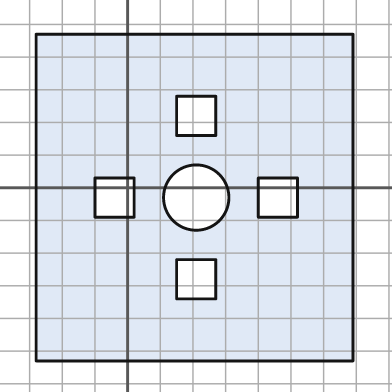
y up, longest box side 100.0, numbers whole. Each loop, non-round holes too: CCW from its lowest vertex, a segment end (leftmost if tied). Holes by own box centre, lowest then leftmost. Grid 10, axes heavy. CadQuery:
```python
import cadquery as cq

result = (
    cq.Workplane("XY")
    .moveTo(-28.0, -53.0)
    .lineTo(69.0, -53.0)
    .lineTo(69.0, 47.0)
    .lineTo(-28.0, 47.0)
    .close()
    .moveTo(15.0, -34.0)
    .lineTo(27.0, -34.0)
    .lineTo(27.0, -22.0)
    .lineTo(15.0, -22.0)
    .close()
    .moveTo(-10.0, -9.0)
    .lineTo(2.0, -9.0)
    .lineTo(2.0, 3.0)
    .lineTo(-10.0, 3.0)
    .close()
    .moveTo(21.0, -3.0)
    .circle(10.0)
    .moveTo(40.0, -9.0)
    .lineTo(52.0, -9.0)
    .lineTo(52.0, 3.0)
    .lineTo(40.0, 3.0)
    .close()
    .moveTo(15.0, 16.0)
    .lineTo(27.0, 16.0)
    .lineTo(27.0, 28.0)
    .lineTo(15.0, 28.0)
    .close()
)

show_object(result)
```